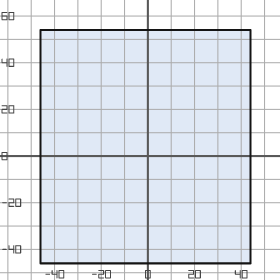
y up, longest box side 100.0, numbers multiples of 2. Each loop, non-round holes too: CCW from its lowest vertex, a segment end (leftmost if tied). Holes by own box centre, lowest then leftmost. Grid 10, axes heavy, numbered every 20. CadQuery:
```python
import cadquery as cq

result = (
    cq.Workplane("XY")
    .moveTo(-46.0, -46.0)
    .lineTo(44.0, -46.0)
    .lineTo(44.0, 54.0)
    .lineTo(-46.0, 54.0)
    .close()
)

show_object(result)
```